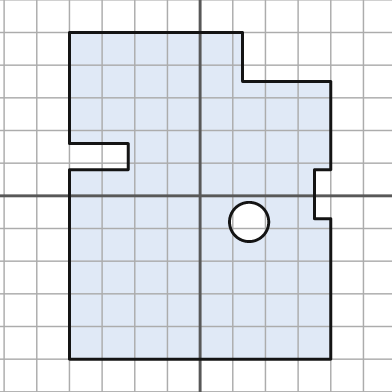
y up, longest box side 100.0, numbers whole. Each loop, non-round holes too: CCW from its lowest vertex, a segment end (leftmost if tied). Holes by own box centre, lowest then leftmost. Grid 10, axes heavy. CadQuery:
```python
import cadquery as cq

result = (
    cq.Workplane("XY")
    .moveTo(-40.0, -50.0)
    .lineTo(40.0, -50.0)
    .lineTo(40.0, -7.0)
    .lineTo(35.0, -7.0)
    .lineTo(35.0, 8.0)
    .lineTo(40.0, 8.0)
    .lineTo(40.0, 35.0)
    .lineTo(13.0, 35.0)
    .lineTo(13.0, 50.0)
    .lineTo(-40.0, 50.0)
    .lineTo(-40.0, 16.0)
    .lineTo(-22.0, 16.0)
    .lineTo(-22.0, 8.0)
    .lineTo(-40.0, 8.0)
    .close()
    .moveTo(15.0, -8.0)
    .circle(6.0)
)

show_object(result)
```